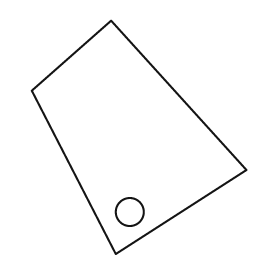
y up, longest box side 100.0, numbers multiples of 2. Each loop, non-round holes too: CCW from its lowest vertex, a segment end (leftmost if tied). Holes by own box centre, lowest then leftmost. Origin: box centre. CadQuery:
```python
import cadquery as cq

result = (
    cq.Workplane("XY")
    .moveTo(-10.0, -50.0)
    .lineTo(46.0, -14.0)
    .lineTo(-12.0, 50.0)
    .lineTo(-46.0, 20.0)
    .close()
    .moveTo(-4.0, -32.0)
    .circle(6.0)
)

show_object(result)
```